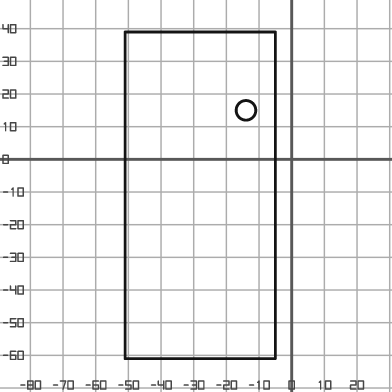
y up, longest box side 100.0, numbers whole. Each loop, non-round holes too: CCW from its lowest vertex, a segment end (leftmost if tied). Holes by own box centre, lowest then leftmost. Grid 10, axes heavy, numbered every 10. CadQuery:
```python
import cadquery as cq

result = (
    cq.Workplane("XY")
    .moveTo(-51.0, -61.0)
    .lineTo(-5.0, -61.0)
    .lineTo(-5.0, 39.0)
    .lineTo(-51.0, 39.0)
    .close()
    .moveTo(-14.0, 15.0)
    .circle(3.0)
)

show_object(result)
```